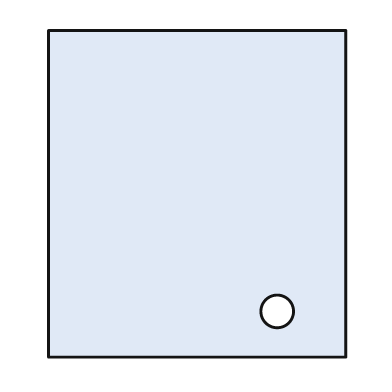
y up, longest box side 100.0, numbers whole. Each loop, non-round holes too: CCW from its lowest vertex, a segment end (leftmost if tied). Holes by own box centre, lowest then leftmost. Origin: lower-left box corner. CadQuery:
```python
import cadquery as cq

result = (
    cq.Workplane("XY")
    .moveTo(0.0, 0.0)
    .lineTo(91.0, 0.0)
    .lineTo(91.0, 100.0)
    .lineTo(0.0, 100.0)
    .close()
    .moveTo(70.0, 14.0)
    .circle(5.0)
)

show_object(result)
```